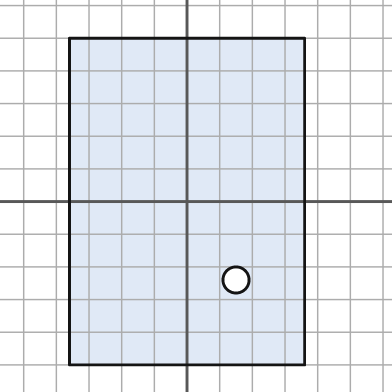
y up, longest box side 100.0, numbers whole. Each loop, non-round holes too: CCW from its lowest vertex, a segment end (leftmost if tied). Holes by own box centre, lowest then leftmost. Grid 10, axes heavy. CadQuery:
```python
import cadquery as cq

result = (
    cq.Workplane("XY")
    .moveTo(-36.0, -50.0)
    .lineTo(36.0, -50.0)
    .lineTo(36.0, 50.0)
    .lineTo(-36.0, 50.0)
    .close()
    .moveTo(15.0, -24.0)
    .circle(4.0)
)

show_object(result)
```